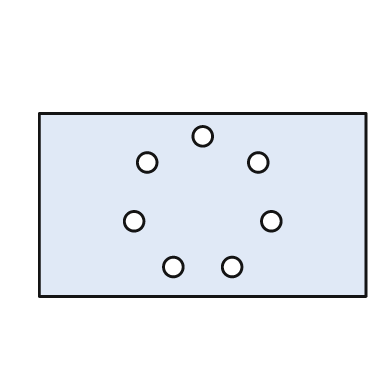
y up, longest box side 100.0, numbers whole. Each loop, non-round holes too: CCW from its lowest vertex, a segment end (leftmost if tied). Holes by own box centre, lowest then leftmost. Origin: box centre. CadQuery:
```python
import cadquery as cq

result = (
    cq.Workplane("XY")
    .moveTo(-50.0, -28.0)
    .lineTo(50.0, -28.0)
    .lineTo(50.0, 28.0)
    .lineTo(-50.0, 28.0)
    .close()
    .moveTo(-9.0, -19.0)
    .circle(3.0)
    .moveTo(9.0, -19.0)
    .circle(3.0)
    .moveTo(-21.0, -5.0)
    .circle(3.0)
    .moveTo(21.0, -5.0)
    .circle(3.0)
    .moveTo(-17.0, 13.0)
    .circle(3.0)
    .moveTo(17.0, 13.0)
    .circle(3.0)
    .moveTo(0.0, 21.0)
    .circle(3.0)
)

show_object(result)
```